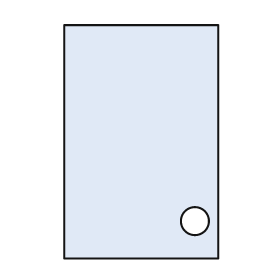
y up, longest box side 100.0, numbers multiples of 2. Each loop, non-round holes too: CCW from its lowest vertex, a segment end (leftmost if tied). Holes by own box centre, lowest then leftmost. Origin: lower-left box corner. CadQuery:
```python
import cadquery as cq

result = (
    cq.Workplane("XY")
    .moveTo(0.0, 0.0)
    .lineTo(66.0, 0.0)
    .lineTo(66.0, 100.0)
    .lineTo(0.0, 100.0)
    .close()
    .moveTo(56.0, 16.0)
    .circle(6.0)
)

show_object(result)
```